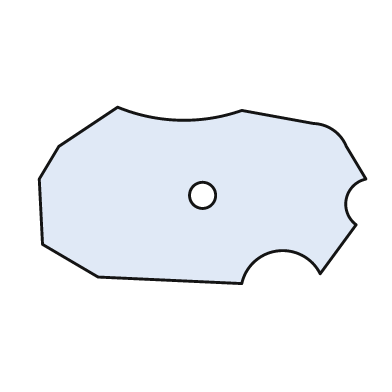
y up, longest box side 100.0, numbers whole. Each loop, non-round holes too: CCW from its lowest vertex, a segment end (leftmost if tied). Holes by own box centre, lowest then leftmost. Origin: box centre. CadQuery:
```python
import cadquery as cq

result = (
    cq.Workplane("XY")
    .moveTo(12.0, -27.0)
    .threePointArc((23.0, -17.0), (36.0, -24.0))
    .lineTo(47.0, -9.0)
    .threePointArc((44.0, -1.0), (50.0, 5.0))
    .lineTo(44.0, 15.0)
    .threePointArc((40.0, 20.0), (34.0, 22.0))
    .lineTo(12.0, 26.0)
    .threePointArc((-7.0, 23.0), (-26.0, 27.0))
    .lineTo(-44.0, 15.0)
    .lineTo(-50.0, 5.0)
    .lineTo(-49.0, -15.0)
    .lineTo(-32.0, -25.0)
    .close()
    .moveTo(0.0, 0.0)
    .circle(4.0)
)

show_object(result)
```